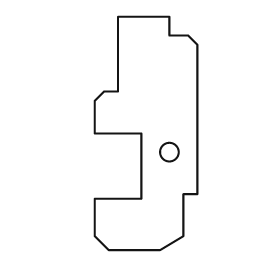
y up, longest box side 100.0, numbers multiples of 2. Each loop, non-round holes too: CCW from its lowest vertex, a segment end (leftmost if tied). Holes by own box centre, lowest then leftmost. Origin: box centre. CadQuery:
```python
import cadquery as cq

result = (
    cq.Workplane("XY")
    .moveTo(-16.0, -50.0)
    .lineTo(6.0, -50.0)
    .lineTo(16.0, -44.0)
    .lineTo(16.0, -26.0)
    .lineTo(22.0, -26.0)
    .lineTo(22.0, 38.0)
    .lineTo(18.0, 42.0)
    .lineTo(10.0, 42.0)
    .lineTo(10.0, 50.0)
    .lineTo(-12.0, 50.0)
    .lineTo(-12.0, 18.0)
    .lineTo(-18.0, 18.0)
    .lineTo(-22.0, 14.0)
    .lineTo(-22.0, 0.0)
    .lineTo(-2.0, 0.0)
    .lineTo(-2.0, -28.0)
    .lineTo(-22.0, -28.0)
    .lineTo(-22.0, -44.0)
    .close()
    .moveTo(10.0, -8.0)
    .circle(4.0)
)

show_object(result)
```